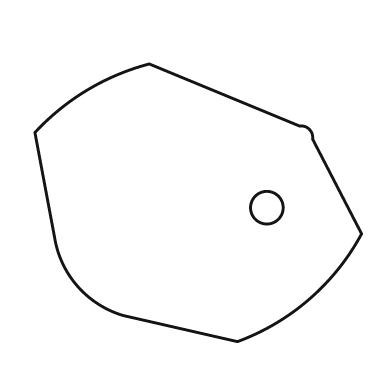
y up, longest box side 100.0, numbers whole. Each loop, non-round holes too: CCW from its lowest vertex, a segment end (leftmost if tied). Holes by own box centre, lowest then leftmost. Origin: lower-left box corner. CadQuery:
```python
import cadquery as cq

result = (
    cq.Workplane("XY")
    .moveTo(62.0, 0.0)
    .threePointArc((84.0, 13.0), (100.0, 33.0))
    .lineTo(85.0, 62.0)
    .threePointArc((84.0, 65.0), (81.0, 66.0))
    .lineTo(35.0, 85.0)
    .threePointArc((16.0, 77.0), (0.0, 64.0))
    .lineTo(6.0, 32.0)
    .threePointArc((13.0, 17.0), (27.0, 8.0))
    .close()
    .moveTo(71.0, 41.0)
    .circle(5.0)
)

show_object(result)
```